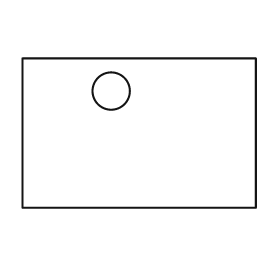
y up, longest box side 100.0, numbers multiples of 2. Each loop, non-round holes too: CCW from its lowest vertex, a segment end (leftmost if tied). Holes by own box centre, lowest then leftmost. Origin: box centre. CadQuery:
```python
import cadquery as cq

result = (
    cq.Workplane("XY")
    .moveTo(-50.0, -32.0)
    .lineTo(50.0, -32.0)
    .lineTo(50.0, 32.0)
    .lineTo(-50.0, 32.0)
    .close()
    .moveTo(-12.0, 18.0)
    .circle(8.0)
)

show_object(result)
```